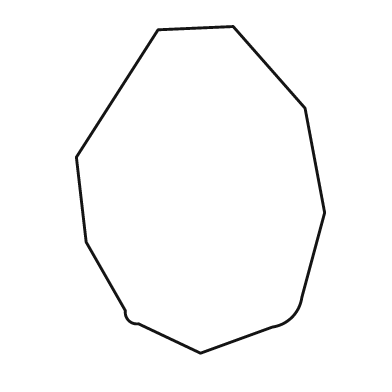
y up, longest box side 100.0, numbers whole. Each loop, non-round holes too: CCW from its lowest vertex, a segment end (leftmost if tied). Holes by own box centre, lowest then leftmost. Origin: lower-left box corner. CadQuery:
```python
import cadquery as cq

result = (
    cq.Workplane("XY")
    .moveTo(38.0, 0.0)
    .lineTo(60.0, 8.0)
    .threePointArc((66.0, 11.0), (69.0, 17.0))
    .lineTo(76.0, 43.0)
    .lineTo(70.0, 75.0)
    .lineTo(48.0, 100.0)
    .lineTo(25.0, 99.0)
    .lineTo(0.0, 60.0)
    .lineTo(3.0, 34.0)
    .lineTo(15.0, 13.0)
    .threePointArc((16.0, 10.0), (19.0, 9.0))
    .close()
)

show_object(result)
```